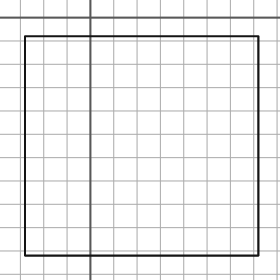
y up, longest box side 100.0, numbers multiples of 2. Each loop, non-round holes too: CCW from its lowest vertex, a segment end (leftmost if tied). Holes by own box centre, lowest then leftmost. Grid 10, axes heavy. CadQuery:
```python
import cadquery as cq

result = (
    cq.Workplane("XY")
    .moveTo(-28.0, -102.0)
    .lineTo(72.0, -102.0)
    .lineTo(72.0, -8.0)
    .lineTo(-28.0, -8.0)
    .close()
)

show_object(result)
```